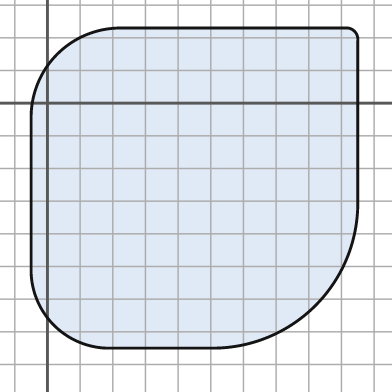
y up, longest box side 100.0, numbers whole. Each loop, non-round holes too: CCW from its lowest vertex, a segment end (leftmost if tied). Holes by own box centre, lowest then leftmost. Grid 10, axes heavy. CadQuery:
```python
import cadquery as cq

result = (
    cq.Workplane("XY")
    .moveTo(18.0, -75.0)
    .lineTo(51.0, -75.0)
    .threePointArc((82.0, -62.0), (95.0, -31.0))
    .lineTo(95.0, 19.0)
    .threePointArc((94.0, 22.0), (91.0, 23.0))
    .lineTo(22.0, 23.0)
    .threePointArc((3.0, 15.0), (-5.0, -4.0))
    .lineTo(-5.0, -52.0)
    .threePointArc((2.0, -68.0), (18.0, -75.0))
    .close()
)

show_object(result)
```